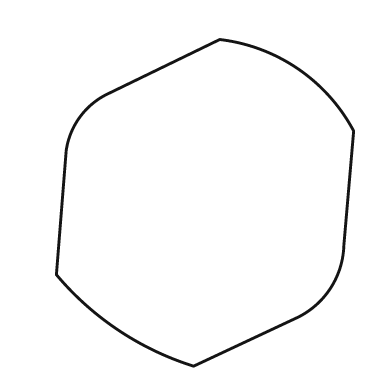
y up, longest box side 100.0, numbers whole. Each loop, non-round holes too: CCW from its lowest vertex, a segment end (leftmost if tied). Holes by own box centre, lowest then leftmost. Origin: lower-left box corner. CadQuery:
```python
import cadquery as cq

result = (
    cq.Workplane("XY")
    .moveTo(42.0, 0.0)
    .lineTo(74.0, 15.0)
    .threePointArc((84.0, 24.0), (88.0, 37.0))
    .lineTo(91.0, 72.0)
    .threePointArc((74.0, 91.0), (50.0, 100.0))
    .lineTo(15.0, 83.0)
    .threePointArc((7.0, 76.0), (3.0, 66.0))
    .lineTo(0.0, 28.0)
    .threePointArc((19.0, 11.0), (42.0, 0.0))
    .close()
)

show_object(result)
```